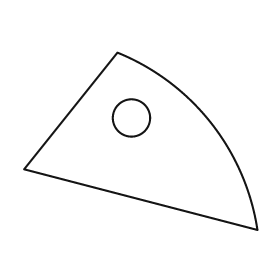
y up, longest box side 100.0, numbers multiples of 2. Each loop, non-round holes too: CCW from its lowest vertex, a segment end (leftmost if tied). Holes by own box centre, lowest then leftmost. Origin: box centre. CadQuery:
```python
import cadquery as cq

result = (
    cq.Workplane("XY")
    .moveTo(50.0, -38.0)
    .threePointArc((30.0, 8.0), (-10.0, 38.0))
    .lineTo(-50.0, -12.0)
    .close()
    .moveTo(-4.0, 10.0)
    .circle(8.0)
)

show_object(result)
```